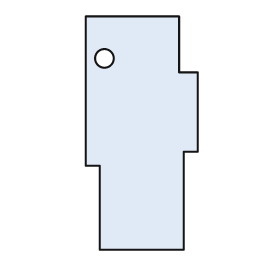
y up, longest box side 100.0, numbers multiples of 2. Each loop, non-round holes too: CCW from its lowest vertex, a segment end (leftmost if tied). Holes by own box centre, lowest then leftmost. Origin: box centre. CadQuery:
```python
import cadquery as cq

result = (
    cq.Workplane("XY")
    .moveTo(-18.0, -50.0)
    .lineTo(18.0, -50.0)
    .lineTo(18.0, -8.0)
    .lineTo(24.0, -8.0)
    .lineTo(24.0, 26.0)
    .lineTo(16.0, 26.0)
    .lineTo(16.0, 50.0)
    .lineTo(-24.0, 50.0)
    .lineTo(-24.0, -14.0)
    .lineTo(-18.0, -14.0)
    .close()
    .moveTo(-16.0, 32.0)
    .circle(4.0)
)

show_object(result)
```